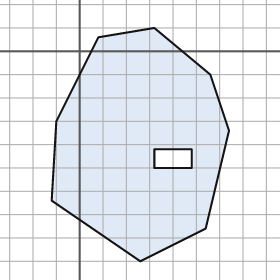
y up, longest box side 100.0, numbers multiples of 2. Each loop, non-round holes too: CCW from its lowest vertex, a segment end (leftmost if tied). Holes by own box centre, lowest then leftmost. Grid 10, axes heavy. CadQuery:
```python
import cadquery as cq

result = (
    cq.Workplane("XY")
    .moveTo(26.0, -90.0)
    .lineTo(54.0, -76.0)
    .lineTo(64.0, -34.0)
    .lineTo(56.0, -10.0)
    .lineTo(32.0, 10.0)
    .lineTo(8.0, 6.0)
    .lineTo(-10.0, -30.0)
    .lineTo(-12.0, -64.0)
    .close()
    .moveTo(32.0, -50.0)
    .lineTo(48.0, -50.0)
    .lineTo(48.0, -42.0)
    .lineTo(32.0, -42.0)
    .close()
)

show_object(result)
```